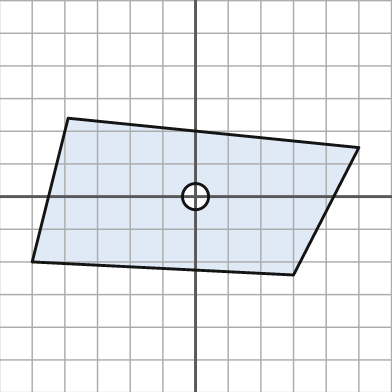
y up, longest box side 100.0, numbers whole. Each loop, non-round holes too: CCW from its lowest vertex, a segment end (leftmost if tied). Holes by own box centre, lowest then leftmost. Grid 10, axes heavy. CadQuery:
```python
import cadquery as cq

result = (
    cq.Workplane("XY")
    .moveTo(30.0, -24.0)
    .lineTo(50.0, 15.0)
    .lineTo(-39.0, 24.0)
    .lineTo(-50.0, -20.0)
    .close()
    .moveTo(0.0, 0.0)
    .circle(4.0)
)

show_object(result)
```